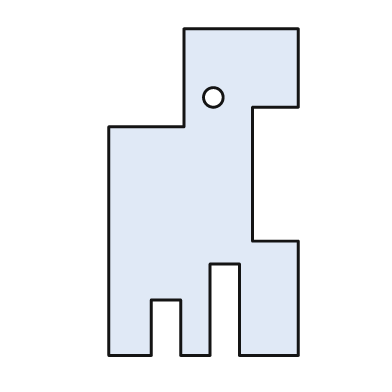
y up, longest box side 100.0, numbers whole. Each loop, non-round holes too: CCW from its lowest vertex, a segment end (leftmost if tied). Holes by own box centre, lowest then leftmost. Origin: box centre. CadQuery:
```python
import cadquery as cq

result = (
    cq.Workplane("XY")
    .moveTo(-29.0, -50.0)
    .lineTo(-16.0, -50.0)
    .lineTo(-16.0, -33.0)
    .lineTo(-7.0, -33.0)
    .lineTo(-7.0, -50.0)
    .lineTo(2.0, -50.0)
    .lineTo(2.0, -22.0)
    .lineTo(11.0, -22.0)
    .lineTo(11.0, -50.0)
    .lineTo(29.0, -50.0)
    .lineTo(29.0, -15.0)
    .lineTo(15.0, -15.0)
    .lineTo(15.0, 26.0)
    .lineTo(29.0, 26.0)
    .lineTo(29.0, 50.0)
    .lineTo(-6.0, 50.0)
    .lineTo(-6.0, 20.0)
    .lineTo(-29.0, 20.0)
    .close()
    .moveTo(3.0, 29.0)
    .circle(3.0)
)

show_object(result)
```